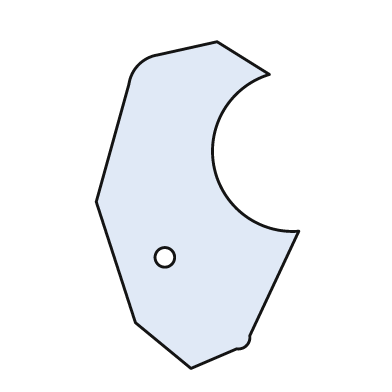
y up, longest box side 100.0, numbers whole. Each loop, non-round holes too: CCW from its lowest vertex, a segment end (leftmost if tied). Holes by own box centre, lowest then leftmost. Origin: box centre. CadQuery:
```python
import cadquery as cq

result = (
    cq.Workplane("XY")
    .moveTo(-2.0, -50.0)
    .lineTo(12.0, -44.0)
    .threePointArc((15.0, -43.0), (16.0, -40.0))
    .lineTo(31.0, -8.0)
    .threePointArc((5.0, 12.0), (22.0, 40.0))
    .lineTo(6.0, 50.0)
    .lineTo(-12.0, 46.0)
    .threePointArc((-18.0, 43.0), (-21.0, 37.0))
    .lineTo(-31.0, 1.0)
    .lineTo(-19.0, -36.0)
    .close()
    .moveTo(-10.0, -16.0)
    .circle(3.0)
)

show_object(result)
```